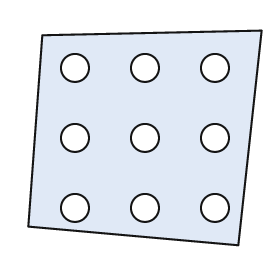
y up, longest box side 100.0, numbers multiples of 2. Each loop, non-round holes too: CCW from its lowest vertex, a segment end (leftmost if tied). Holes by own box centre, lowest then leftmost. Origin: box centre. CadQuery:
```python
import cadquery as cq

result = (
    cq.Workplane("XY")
    .moveTo(40.0, -46.0)
    .lineTo(50.0, 46.0)
    .lineTo(-44.0, 44.0)
    .lineTo(-50.0, -38.0)
    .close()
    .moveTo(-30.0, -30.0)
    .circle(6.0)
    .moveTo(0.0, -30.0)
    .circle(6.0)
    .moveTo(30.0, -30.0)
    .circle(6.0)
    .moveTo(-30.0, 0.0)
    .circle(6.0)
    .moveTo(0.0, 0.0)
    .circle(6.0)
    .moveTo(30.0, 0.0)
    .circle(6.0)
    .moveTo(-30.0, 30.0)
    .circle(6.0)
    .moveTo(0.0, 30.0)
    .circle(6.0)
    .moveTo(30.0, 30.0)
    .circle(6.0)
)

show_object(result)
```